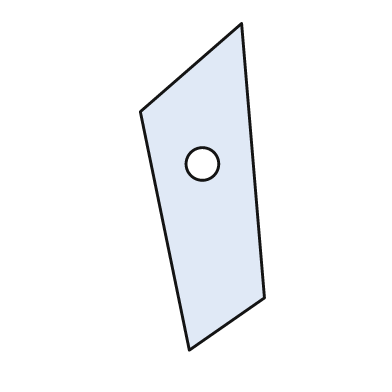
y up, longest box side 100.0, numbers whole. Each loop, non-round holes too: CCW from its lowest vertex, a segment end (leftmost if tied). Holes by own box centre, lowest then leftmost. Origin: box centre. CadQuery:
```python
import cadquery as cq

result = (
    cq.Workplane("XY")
    .moveTo(-4.0, -50.0)
    .lineTo(19.0, -34.0)
    .lineTo(12.0, 50.0)
    .lineTo(-19.0, 23.0)
    .close()
    .moveTo(0.0, 7.0)
    .circle(5.0)
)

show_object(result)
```